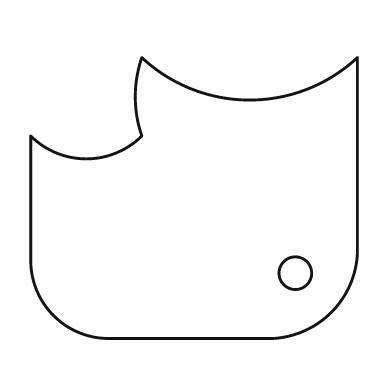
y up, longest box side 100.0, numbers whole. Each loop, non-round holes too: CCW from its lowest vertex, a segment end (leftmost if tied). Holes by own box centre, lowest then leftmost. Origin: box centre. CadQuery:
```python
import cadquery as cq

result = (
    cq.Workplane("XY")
    .moveTo(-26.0, -43.0)
    .lineTo(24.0, -43.0)
    .threePointArc((42.0, -35.0), (50.0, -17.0))
    .lineTo(50.0, 43.0)
    .threePointArc((17.0, 30.0), (-16.0, 43.0))
    .threePointArc((-18.0, 31.0), (-16.0, 19.0))
    .threePointArc((-33.0, 12.0), (-50.0, 19.0))
    .lineTo(-50.0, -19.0)
    .threePointArc((-43.0, -36.0), (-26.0, -43.0))
    .close()
    .moveTo(31.0, -23.0)
    .circle(5.0)
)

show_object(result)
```